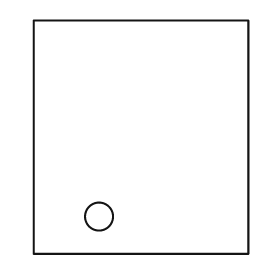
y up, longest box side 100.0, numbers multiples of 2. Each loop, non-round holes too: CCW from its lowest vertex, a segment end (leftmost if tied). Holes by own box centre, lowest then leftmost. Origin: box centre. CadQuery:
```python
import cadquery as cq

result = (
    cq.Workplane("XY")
    .moveTo(-46.0, -50.0)
    .lineTo(46.0, -50.0)
    .lineTo(46.0, 50.0)
    .lineTo(-46.0, 50.0)
    .close()
    .moveTo(-18.0, -34.0)
    .circle(6.0)
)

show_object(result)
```